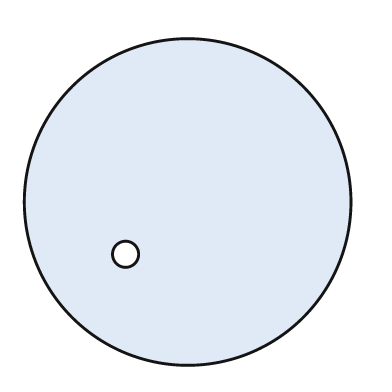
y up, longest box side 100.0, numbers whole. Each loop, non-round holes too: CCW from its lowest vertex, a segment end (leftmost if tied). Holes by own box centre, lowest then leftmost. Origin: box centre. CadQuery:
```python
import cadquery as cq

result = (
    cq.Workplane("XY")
    .moveTo(0.0, 0.0)
    .circle(50.0)
    .moveTo(-19.0, -16.0)
    .circle(4.0)
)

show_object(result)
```